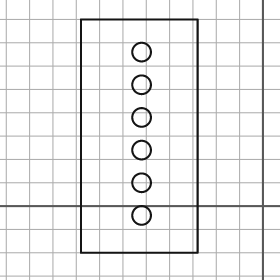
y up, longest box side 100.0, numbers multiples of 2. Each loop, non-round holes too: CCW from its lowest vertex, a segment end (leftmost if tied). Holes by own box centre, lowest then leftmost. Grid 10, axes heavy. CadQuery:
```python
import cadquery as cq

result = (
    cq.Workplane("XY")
    .moveTo(-78.0, -20.0)
    .lineTo(-28.0, -20.0)
    .lineTo(-28.0, 80.0)
    .lineTo(-78.0, 80.0)
    .close()
    .moveTo(-52.0, -4.0)
    .circle(4.0)
    .moveTo(-52.0, 10.0)
    .circle(4.0)
    .moveTo(-52.0, 24.0)
    .circle(4.0)
    .moveTo(-52.0, 38.0)
    .circle(4.0)
    .moveTo(-52.0, 52.0)
    .circle(4.0)
    .moveTo(-52.0, 66.0)
    .circle(4.0)
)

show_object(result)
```